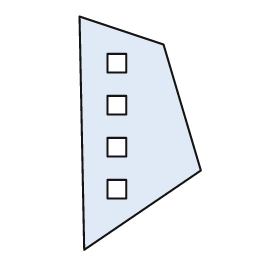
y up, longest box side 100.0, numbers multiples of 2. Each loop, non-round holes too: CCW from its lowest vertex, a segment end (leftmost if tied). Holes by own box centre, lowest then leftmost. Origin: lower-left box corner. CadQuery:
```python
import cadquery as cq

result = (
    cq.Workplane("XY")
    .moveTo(2.0, 0.0)
    .lineTo(52.0, 34.0)
    .lineTo(36.0, 88.0)
    .lineTo(0.0, 100.0)
    .close()
    .moveTo(12.0, 22.0)
    .lineTo(20.0, 22.0)
    .lineTo(20.0, 30.0)
    .lineTo(12.0, 30.0)
    .close()
    .moveTo(12.0, 40.0)
    .lineTo(20.0, 40.0)
    .lineTo(20.0, 48.0)
    .lineTo(12.0, 48.0)
    .close()
    .moveTo(12.0, 58.0)
    .lineTo(20.0, 58.0)
    .lineTo(20.0, 66.0)
    .lineTo(12.0, 66.0)
    .close()
    .moveTo(12.0, 76.0)
    .lineTo(20.0, 76.0)
    .lineTo(20.0, 84.0)
    .lineTo(12.0, 84.0)
    .close()
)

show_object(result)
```